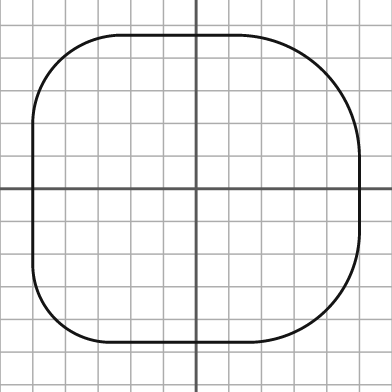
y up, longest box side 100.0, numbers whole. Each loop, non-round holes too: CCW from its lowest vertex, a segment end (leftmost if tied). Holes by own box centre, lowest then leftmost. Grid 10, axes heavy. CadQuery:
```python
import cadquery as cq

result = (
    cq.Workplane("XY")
    .moveTo(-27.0, -47.0)
    .lineTo(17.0, -47.0)
    .threePointArc((40.0, -37.0), (50.0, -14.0))
    .lineTo(50.0, 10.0)
    .threePointArc((39.0, 36.0), (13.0, 47.0))
    .lineTo(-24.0, 47.0)
    .threePointArc((-42.0, 39.0), (-50.0, 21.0))
    .lineTo(-50.0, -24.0)
    .threePointArc((-43.0, -40.0), (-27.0, -47.0))
    .close()
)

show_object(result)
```